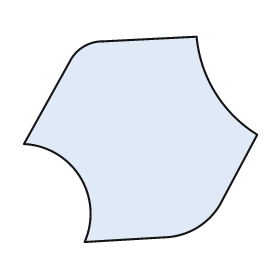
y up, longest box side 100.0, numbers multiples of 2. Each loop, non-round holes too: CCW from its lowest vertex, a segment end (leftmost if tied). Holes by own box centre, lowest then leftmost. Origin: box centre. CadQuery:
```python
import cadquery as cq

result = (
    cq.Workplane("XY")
    .moveTo(-24.0, -44.0)
    .lineTo(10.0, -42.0)
    .threePointArc((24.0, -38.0), (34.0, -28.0))
    .lineTo(50.0, 2.0)
    .threePointArc((32.0, 20.0), (24.0, 44.0))
    .lineTo(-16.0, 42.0)
    .threePointArc((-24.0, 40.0), (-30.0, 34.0))
    .lineTo(-50.0, -2.0)
    .threePointArc((-26.0, -16.0), (-24.0, -44.0))
    .close()
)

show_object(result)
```